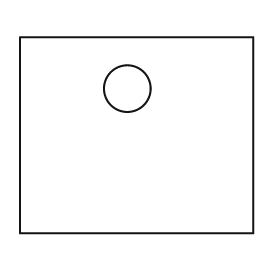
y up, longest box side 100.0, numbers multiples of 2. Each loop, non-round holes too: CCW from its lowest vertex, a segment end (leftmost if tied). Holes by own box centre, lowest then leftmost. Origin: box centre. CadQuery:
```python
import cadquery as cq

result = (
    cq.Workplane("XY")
    .moveTo(-50.0, -42.0)
    .lineTo(50.0, -42.0)
    .lineTo(50.0, 42.0)
    .lineTo(-50.0, 42.0)
    .close()
    .moveTo(-4.0, 20.0)
    .circle(10.0)
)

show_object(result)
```